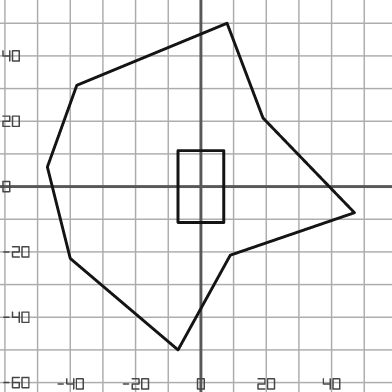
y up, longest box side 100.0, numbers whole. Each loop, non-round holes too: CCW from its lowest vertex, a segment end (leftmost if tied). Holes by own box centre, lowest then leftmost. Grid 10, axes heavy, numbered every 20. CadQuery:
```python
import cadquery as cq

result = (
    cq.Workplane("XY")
    .moveTo(-7.0, -50.0)
    .lineTo(9.0, -21.0)
    .lineTo(47.0, -8.0)
    .lineTo(19.0, 21.0)
    .lineTo(8.0, 50.0)
    .lineTo(-38.0, 31.0)
    .lineTo(-47.0, 6.0)
    .lineTo(-40.0, -22.0)
    .close()
    .moveTo(-7.0, -11.0)
    .lineTo(7.0, -11.0)
    .lineTo(7.0, 11.0)
    .lineTo(-7.0, 11.0)
    .close()
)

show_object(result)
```